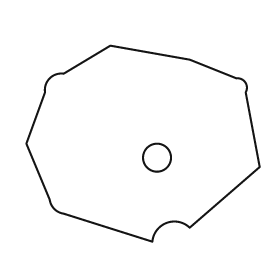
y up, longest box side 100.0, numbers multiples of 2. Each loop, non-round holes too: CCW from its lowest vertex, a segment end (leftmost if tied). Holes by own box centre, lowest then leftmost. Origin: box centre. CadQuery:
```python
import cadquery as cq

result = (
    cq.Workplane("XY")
    .moveTo(4.0, -42.0)
    .threePointArc((10.0, -34.0), (20.0, -36.0))
    .lineTo(50.0, -10.0)
    .lineTo(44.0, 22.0)
    .threePointArc((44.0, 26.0), (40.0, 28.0))
    .lineTo(20.0, 36.0)
    .lineTo(-14.0, 42.0)
    .lineTo(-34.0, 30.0)
    .threePointArc((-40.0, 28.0), (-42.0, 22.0))
    .lineTo(-50.0, 0.0)
    .lineTo(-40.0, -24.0)
    .threePointArc((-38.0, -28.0), (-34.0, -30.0))
    .close()
    .moveTo(6.0, -6.0)
    .circle(6.0)
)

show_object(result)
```